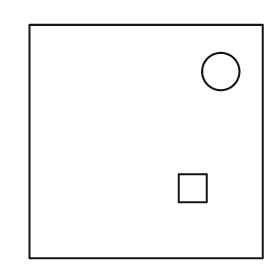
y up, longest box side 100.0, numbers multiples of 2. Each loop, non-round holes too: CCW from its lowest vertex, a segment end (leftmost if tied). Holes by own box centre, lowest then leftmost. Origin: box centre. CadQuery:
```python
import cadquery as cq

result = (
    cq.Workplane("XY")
    .moveTo(-50.0, -50.0)
    .lineTo(50.0, -50.0)
    .lineTo(50.0, 50.0)
    .lineTo(-50.0, 50.0)
    .close()
    .moveTo(14.0, -26.0)
    .lineTo(26.0, -26.0)
    .lineTo(26.0, -14.0)
    .lineTo(14.0, -14.0)
    .close()
    .moveTo(32.0, 30.0)
    .circle(8.0)
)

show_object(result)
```